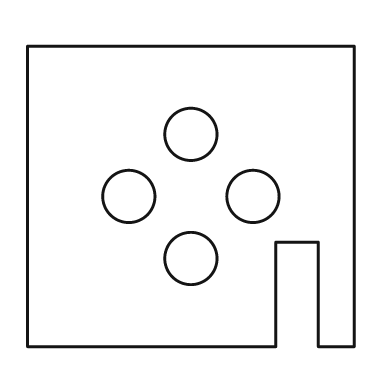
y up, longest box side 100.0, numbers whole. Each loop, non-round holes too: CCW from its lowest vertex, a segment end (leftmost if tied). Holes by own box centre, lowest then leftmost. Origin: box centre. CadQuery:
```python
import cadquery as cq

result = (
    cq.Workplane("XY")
    .moveTo(-50.0, -46.0)
    .lineTo(26.0, -46.0)
    .lineTo(26.0, -14.0)
    .lineTo(39.0, -14.0)
    .lineTo(39.0, -46.0)
    .lineTo(50.0, -46.0)
    .lineTo(50.0, 46.0)
    .lineTo(-50.0, 46.0)
    .close()
    .moveTo(0.0, -19.0)
    .circle(8.0)
    .moveTo(-19.0, 0.0)
    .circle(8.0)
    .moveTo(19.0, 0.0)
    .circle(8.0)
    .moveTo(0.0, 19.0)
    .circle(8.0)
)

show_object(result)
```